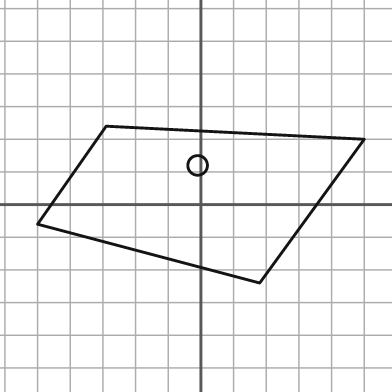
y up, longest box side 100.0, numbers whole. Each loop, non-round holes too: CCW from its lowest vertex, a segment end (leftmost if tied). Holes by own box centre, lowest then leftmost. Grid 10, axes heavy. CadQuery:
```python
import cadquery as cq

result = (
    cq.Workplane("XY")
    .moveTo(18.0, -24.0)
    .lineTo(50.0, 20.0)
    .lineTo(-29.0, 24.0)
    .lineTo(-50.0, -6.0)
    .close()
    .moveTo(-1.0, 12.0)
    .circle(3.0)
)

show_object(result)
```